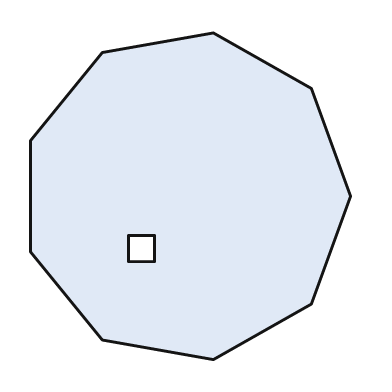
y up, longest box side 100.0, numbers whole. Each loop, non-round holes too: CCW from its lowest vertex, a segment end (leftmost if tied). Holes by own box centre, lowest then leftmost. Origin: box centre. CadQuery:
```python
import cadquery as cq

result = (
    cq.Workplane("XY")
    .moveTo(7.0, -50.0)
    .lineTo(37.0, -33.0)
    .lineTo(49.0, 0.0)
    .lineTo(37.0, 33.0)
    .lineTo(7.0, 50.0)
    .lineTo(-27.0, 44.0)
    .lineTo(-49.0, 17.0)
    .lineTo(-49.0, -17.0)
    .lineTo(-27.0, -44.0)
    .close()
    .moveTo(-19.0, -20.0)
    .lineTo(-11.0, -20.0)
    .lineTo(-11.0, -12.0)
    .lineTo(-19.0, -12.0)
    .close()
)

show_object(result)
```